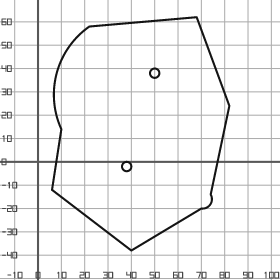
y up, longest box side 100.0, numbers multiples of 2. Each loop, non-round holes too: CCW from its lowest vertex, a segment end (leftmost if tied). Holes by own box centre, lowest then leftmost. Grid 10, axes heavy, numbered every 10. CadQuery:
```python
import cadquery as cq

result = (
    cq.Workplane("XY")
    .moveTo(40.0, -38.0)
    .lineTo(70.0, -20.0)
    .threePointArc((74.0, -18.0), (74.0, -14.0))
    .lineTo(82.0, 24.0)
    .lineTo(68.0, 62.0)
    .lineTo(22.0, 58.0)
    .threePointArc((8.0, 38.0), (10.0, 14.0))
    .lineTo(6.0, -12.0)
    .close()
    .moveTo(38.0, -2.0)
    .circle(2.0)
    .moveTo(50.0, 38.0)
    .circle(2.0)
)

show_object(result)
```